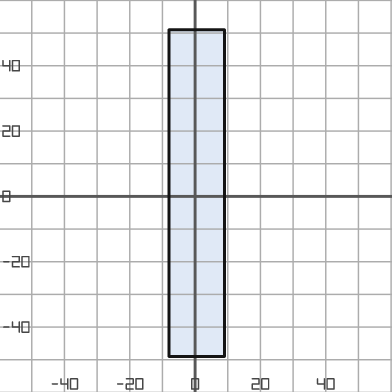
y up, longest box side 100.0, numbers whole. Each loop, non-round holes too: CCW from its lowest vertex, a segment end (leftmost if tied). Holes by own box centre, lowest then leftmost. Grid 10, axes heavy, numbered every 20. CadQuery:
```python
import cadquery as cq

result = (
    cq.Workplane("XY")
    .moveTo(-8.0, -49.0)
    .lineTo(9.0, -49.0)
    .lineTo(9.0, 51.0)
    .lineTo(-8.0, 51.0)
    .close()
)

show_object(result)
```